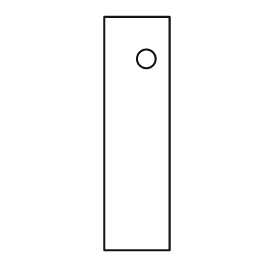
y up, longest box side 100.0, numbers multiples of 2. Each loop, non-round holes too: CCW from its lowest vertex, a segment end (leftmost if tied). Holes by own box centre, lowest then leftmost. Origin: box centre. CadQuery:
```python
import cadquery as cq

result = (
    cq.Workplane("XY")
    .moveTo(-14.0, -50.0)
    .lineTo(14.0, -50.0)
    .lineTo(14.0, 50.0)
    .lineTo(-14.0, 50.0)
    .close()
    .moveTo(4.0, 32.0)
    .circle(4.0)
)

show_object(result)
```